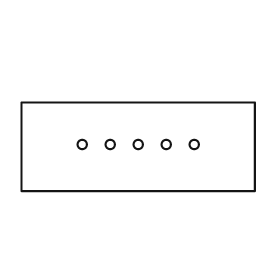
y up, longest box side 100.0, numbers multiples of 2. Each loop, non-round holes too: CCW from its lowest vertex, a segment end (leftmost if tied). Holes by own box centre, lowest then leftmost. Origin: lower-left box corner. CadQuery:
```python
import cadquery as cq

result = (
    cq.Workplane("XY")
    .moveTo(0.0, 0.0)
    .lineTo(100.0, 0.0)
    .lineTo(100.0, 38.0)
    .lineTo(0.0, 38.0)
    .close()
    .moveTo(26.0, 20.0)
    .circle(2.0)
    .moveTo(38.0, 20.0)
    .circle(2.0)
    .moveTo(50.0, 20.0)
    .circle(2.0)
    .moveTo(62.0, 20.0)
    .circle(2.0)
    .moveTo(74.0, 20.0)
    .circle(2.0)
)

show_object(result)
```